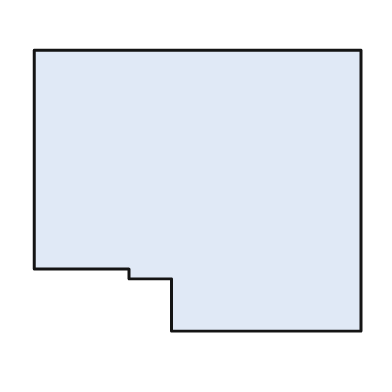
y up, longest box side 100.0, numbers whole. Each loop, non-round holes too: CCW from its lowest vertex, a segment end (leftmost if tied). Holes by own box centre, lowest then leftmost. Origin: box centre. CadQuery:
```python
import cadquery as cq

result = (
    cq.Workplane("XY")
    .moveTo(-8.0, -43.0)
    .lineTo(50.0, -43.0)
    .lineTo(50.0, 43.0)
    .lineTo(-50.0, 43.0)
    .lineTo(-50.0, -24.0)
    .lineTo(-21.0, -24.0)
    .lineTo(-21.0, -27.0)
    .lineTo(-8.0, -27.0)
    .close()
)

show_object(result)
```